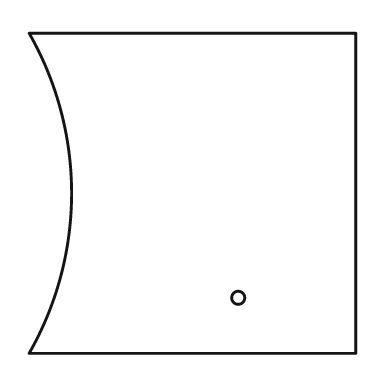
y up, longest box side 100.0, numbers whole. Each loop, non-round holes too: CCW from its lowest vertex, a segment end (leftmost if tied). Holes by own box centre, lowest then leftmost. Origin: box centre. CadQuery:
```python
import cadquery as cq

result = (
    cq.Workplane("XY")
    .moveTo(-50.0, -49.0)
    .lineTo(50.0, -49.0)
    .lineTo(50.0, 49.0)
    .lineTo(-50.0, 49.0)
    .threePointArc((-37.0, 0.0), (-50.0, -49.0))
    .close()
    .moveTo(14.0, -32.0)
    .circle(2.0)
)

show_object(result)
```